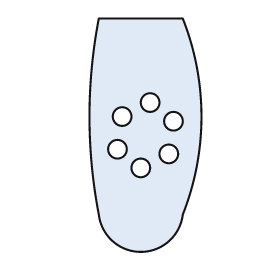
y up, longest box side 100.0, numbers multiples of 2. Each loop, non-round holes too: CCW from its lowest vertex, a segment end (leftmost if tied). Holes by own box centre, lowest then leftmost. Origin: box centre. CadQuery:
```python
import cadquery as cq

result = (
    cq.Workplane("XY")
    .moveTo(-20.0, -34.0)
    .threePointArc((-2.0, -50.0), (16.0, -34.0))
    .threePointArc((24.0, 8.0), (16.0, 50.0))
    .lineTo(-20.0, 50.0)
    .threePointArc((-24.0, 8.0), (-20.0, -34.0))
    .close()
    .moveTo(-2.0, -14.0)
    .circle(4.0)
    .moveTo(10.0, -8.0)
    .circle(4.0)
    .moveTo(-12.0, -6.0)
    .circle(4.0)
    .moveTo(12.0, 6.0)
    .circle(4.0)
    .moveTo(-10.0, 8.0)
    .circle(4.0)
    .moveTo(2.0, 14.0)
    .circle(4.0)
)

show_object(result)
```